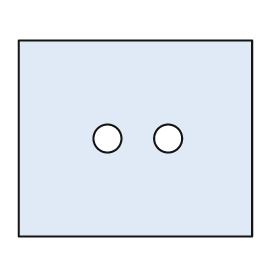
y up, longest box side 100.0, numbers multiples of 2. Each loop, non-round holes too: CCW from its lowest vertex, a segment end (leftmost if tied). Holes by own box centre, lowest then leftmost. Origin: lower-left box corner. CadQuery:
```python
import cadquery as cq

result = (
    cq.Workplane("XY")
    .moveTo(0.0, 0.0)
    .lineTo(100.0, 0.0)
    .lineTo(100.0, 84.0)
    .lineTo(0.0, 84.0)
    .close()
    .moveTo(38.0, 42.0)
    .circle(6.0)
    .moveTo(64.0, 42.0)
    .circle(6.0)
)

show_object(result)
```